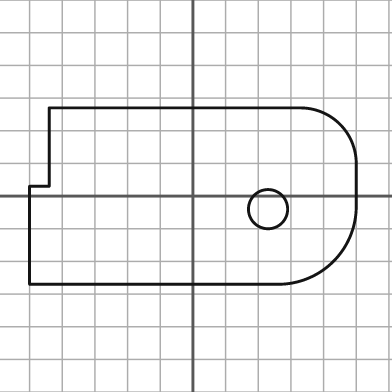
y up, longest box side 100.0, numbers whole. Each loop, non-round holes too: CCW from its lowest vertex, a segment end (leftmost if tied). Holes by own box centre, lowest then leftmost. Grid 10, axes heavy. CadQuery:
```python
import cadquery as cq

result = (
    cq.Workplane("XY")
    .moveTo(-50.0, -27.0)
    .lineTo(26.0, -27.0)
    .threePointArc((43.0, -20.0), (50.0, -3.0))
    .lineTo(50.0, 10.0)
    .threePointArc((45.0, 22.0), (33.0, 27.0))
    .lineTo(-44.0, 27.0)
    .lineTo(-44.0, 3.0)
    .lineTo(-50.0, 3.0)
    .close()
    .moveTo(23.0, -4.0)
    .circle(6.0)
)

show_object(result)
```